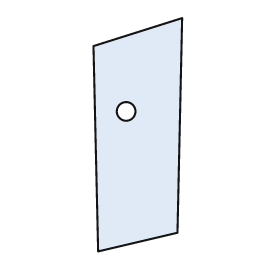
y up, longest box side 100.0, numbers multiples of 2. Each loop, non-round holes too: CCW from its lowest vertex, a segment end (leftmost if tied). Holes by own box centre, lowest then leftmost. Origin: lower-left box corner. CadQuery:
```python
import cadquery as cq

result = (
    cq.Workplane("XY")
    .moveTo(2.0, 0.0)
    .lineTo(36.0, 8.0)
    .lineTo(38.0, 100.0)
    .lineTo(0.0, 88.0)
    .close()
    .moveTo(14.0, 60.0)
    .circle(4.0)
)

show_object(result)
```